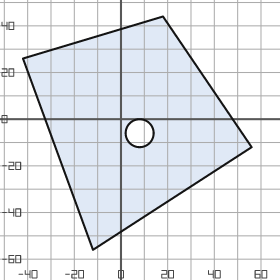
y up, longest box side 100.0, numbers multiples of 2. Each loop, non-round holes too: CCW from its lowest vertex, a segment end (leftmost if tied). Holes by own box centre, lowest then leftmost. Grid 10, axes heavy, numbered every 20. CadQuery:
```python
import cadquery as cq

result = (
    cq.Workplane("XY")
    .moveTo(-12.0, -56.0)
    .lineTo(56.0, -12.0)
    .lineTo(18.0, 44.0)
    .lineTo(-42.0, 26.0)
    .close()
    .moveTo(8.0, -6.0)
    .circle(6.0)
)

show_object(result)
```